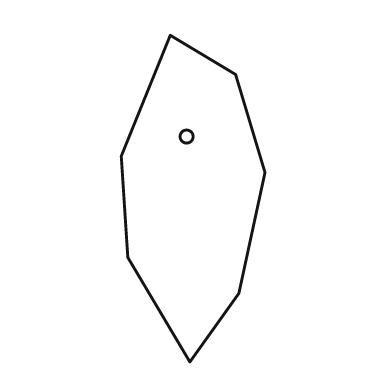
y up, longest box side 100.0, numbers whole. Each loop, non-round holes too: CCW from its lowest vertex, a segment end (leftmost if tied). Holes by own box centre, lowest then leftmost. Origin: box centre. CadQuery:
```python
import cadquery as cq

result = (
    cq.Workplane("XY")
    .moveTo(-1.0, -50.0)
    .lineTo(14.0, -29.0)
    .lineTo(22.0, 8.0)
    .lineTo(13.0, 38.0)
    .lineTo(-7.0, 50.0)
    .lineTo(-22.0, 13.0)
    .lineTo(-20.0, -18.0)
    .close()
    .moveTo(-2.0, 19.0)
    .circle(2.0)
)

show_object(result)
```